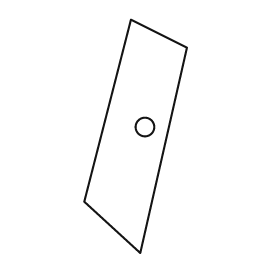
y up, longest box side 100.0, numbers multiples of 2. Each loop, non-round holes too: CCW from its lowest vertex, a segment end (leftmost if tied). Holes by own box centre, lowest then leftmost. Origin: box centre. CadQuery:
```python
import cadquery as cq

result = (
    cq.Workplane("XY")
    .moveTo(2.0, -50.0)
    .lineTo(22.0, 38.0)
    .lineTo(-2.0, 50.0)
    .lineTo(-22.0, -28.0)
    .close()
    .moveTo(4.0, 4.0)
    .circle(4.0)
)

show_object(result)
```